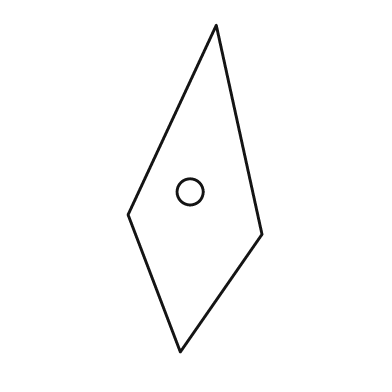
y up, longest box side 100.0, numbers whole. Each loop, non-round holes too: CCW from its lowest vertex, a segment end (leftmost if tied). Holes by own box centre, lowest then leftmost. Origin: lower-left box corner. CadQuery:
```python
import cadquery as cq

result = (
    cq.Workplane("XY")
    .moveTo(16.0, 0.0)
    .lineTo(41.0, 36.0)
    .lineTo(27.0, 100.0)
    .lineTo(0.0, 42.0)
    .close()
    .moveTo(19.0, 49.0)
    .circle(4.0)
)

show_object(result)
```